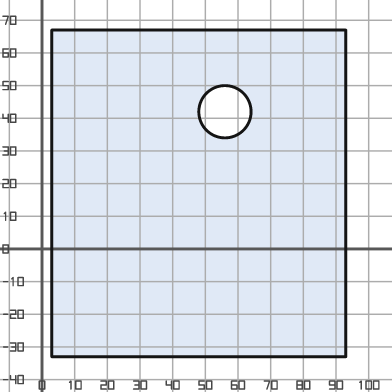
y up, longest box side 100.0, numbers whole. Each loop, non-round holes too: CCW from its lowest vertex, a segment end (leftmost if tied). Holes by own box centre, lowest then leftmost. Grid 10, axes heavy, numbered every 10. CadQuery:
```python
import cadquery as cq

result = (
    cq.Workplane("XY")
    .moveTo(3.0, -33.0)
    .lineTo(93.0, -33.0)
    .lineTo(93.0, 67.0)
    .lineTo(3.0, 67.0)
    .close()
    .moveTo(56.0, 42.0)
    .circle(8.0)
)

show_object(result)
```